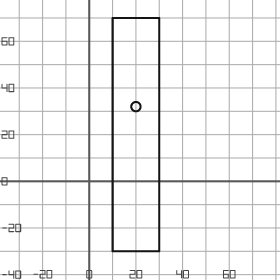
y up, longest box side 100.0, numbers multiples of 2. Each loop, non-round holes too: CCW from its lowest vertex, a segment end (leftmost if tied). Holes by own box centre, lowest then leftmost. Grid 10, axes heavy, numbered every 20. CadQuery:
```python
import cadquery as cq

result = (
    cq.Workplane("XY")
    .moveTo(10.0, -30.0)
    .lineTo(30.0, -30.0)
    .lineTo(30.0, 70.0)
    .lineTo(10.0, 70.0)
    .close()
    .moveTo(20.0, 32.0)
    .circle(2.0)
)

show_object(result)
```